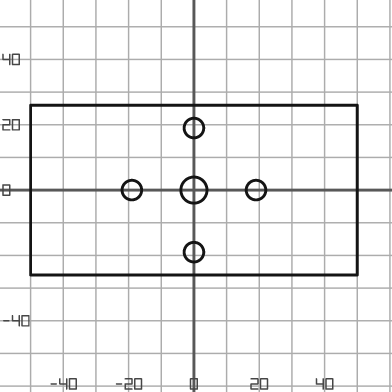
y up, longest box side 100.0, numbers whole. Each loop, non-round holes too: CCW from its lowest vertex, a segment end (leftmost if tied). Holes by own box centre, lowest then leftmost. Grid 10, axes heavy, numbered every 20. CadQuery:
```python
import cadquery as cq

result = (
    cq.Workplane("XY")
    .moveTo(-50.0, -26.0)
    .lineTo(50.0, -26.0)
    .lineTo(50.0, 26.0)
    .lineTo(-50.0, 26.0)
    .close()
    .moveTo(0.0, -19.0)
    .circle(3.0)
    .moveTo(-19.0, 0.0)
    .circle(3.0)
    .moveTo(0.0, 0.0)
    .circle(4.0)
    .moveTo(19.0, 0.0)
    .circle(3.0)
    .moveTo(0.0, 19.0)
    .circle(3.0)
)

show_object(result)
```